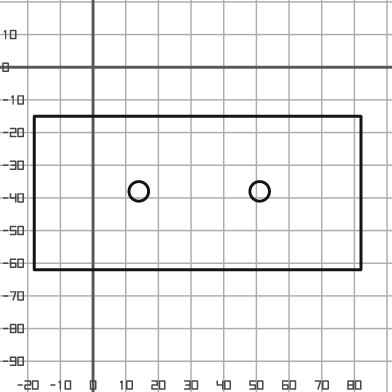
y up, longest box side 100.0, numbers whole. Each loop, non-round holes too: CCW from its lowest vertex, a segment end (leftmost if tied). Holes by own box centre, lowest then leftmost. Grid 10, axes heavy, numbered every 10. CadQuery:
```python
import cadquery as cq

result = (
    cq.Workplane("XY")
    .moveTo(-18.0, -62.0)
    .lineTo(82.0, -62.0)
    .lineTo(82.0, -15.0)
    .lineTo(-18.0, -15.0)
    .close()
    .moveTo(14.0, -38.0)
    .circle(3.0)
    .moveTo(51.0, -38.0)
    .circle(3.0)
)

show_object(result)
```